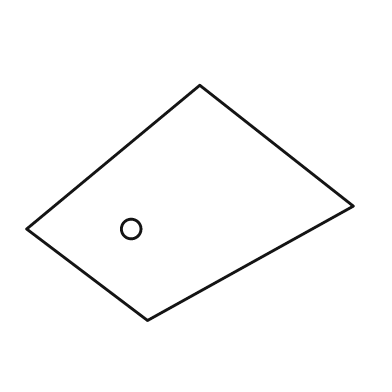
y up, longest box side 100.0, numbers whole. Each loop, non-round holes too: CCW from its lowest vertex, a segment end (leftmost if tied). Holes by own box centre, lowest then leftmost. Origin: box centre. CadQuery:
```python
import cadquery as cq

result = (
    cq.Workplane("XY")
    .moveTo(-13.0, -36.0)
    .lineTo(50.0, -1.0)
    .lineTo(3.0, 36.0)
    .lineTo(-50.0, -8.0)
    .close()
    .moveTo(-18.0, -8.0)
    .circle(3.0)
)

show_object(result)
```